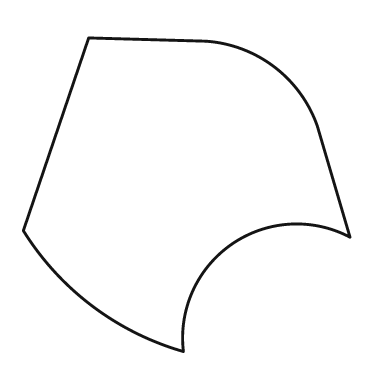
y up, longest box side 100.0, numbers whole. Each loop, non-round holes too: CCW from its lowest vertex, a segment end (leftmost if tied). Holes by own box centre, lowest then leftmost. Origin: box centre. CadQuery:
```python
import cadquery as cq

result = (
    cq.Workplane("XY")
    .moveTo(-1.0, -48.0)
    .threePointArc((14.0, -15.0), (50.0, -13.0))
    .lineTo(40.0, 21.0)
    .threePointArc((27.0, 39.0), (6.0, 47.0))
    .lineTo(-30.0, 48.0)
    .lineTo(-50.0, -11.0)
    .threePointArc((-29.0, -34.0), (-1.0, -48.0))
    .close()
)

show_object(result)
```